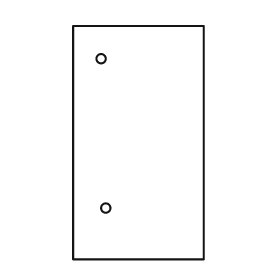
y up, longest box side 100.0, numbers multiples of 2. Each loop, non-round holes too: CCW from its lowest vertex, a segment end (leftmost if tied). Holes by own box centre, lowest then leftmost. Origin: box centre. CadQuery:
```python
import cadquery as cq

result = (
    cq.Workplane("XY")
    .moveTo(-28.0, -50.0)
    .lineTo(28.0, -50.0)
    .lineTo(28.0, 50.0)
    .lineTo(-28.0, 50.0)
    .close()
    .moveTo(-14.0, -28.0)
    .circle(2.0)
    .moveTo(-16.0, 36.0)
    .circle(2.0)
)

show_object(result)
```